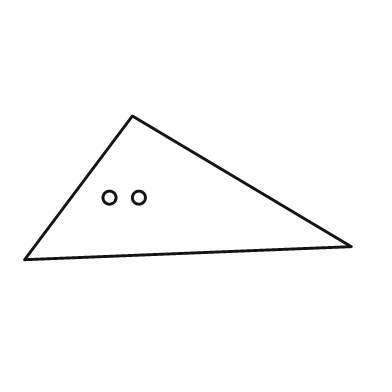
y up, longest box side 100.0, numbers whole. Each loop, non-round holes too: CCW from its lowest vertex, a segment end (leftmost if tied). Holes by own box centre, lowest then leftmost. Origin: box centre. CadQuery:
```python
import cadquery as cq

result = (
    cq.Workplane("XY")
    .moveTo(-50.0, -22.0)
    .lineTo(50.0, -18.0)
    .lineTo(-17.0, 22.0)
    .close()
    .moveTo(-24.0, -3.0)
    .circle(2.0)
    .moveTo(-15.0, -3.0)
    .circle(2.0)
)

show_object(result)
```